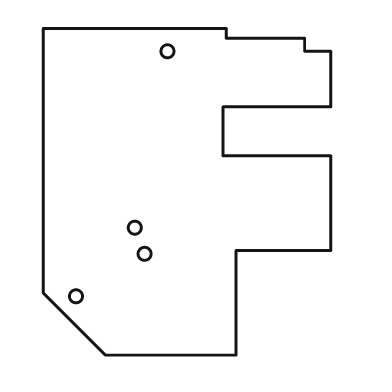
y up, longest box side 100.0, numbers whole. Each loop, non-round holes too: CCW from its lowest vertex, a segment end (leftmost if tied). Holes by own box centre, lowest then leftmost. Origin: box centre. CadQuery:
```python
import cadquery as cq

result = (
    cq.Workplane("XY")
    .moveTo(-25.0, -50.0)
    .lineTo(15.0, -50.0)
    .lineTo(15.0, -18.0)
    .lineTo(44.0, -18.0)
    .lineTo(44.0, 11.0)
    .lineTo(11.0, 11.0)
    .lineTo(11.0, 26.0)
    .lineTo(44.0, 26.0)
    .lineTo(44.0, 43.0)
    .lineTo(36.0, 43.0)
    .lineTo(36.0, 47.0)
    .lineTo(12.0, 47.0)
    .lineTo(12.0, 50.0)
    .lineTo(-44.0, 50.0)
    .lineTo(-44.0, -31.0)
    .close()
    .moveTo(-34.0, -32.0)
    .circle(2.0)
    .moveTo(-13.0, -19.0)
    .circle(2.0)
    .moveTo(-16.0, -11.0)
    .circle(2.0)
    .moveTo(-6.0, 43.0)
    .circle(2.0)
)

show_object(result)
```